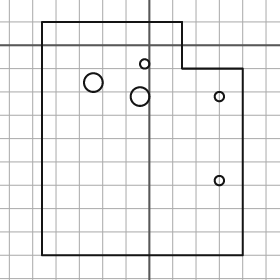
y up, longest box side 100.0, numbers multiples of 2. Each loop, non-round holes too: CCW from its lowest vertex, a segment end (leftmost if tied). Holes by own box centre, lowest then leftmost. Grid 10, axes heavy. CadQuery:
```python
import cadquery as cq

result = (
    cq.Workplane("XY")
    .moveTo(-46.0, -90.0)
    .lineTo(40.0, -90.0)
    .lineTo(40.0, -10.0)
    .lineTo(14.0, -10.0)
    .lineTo(14.0, 10.0)
    .lineTo(-46.0, 10.0)
    .close()
    .moveTo(30.0, -58.0)
    .circle(2.0)
    .moveTo(-4.0, -22.0)
    .circle(4.0)
    .moveTo(30.0, -22.0)
    .circle(2.0)
    .moveTo(-24.0, -16.0)
    .circle(4.0)
    .moveTo(-2.0, -8.0)
    .circle(2.0)
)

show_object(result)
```